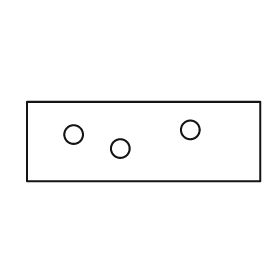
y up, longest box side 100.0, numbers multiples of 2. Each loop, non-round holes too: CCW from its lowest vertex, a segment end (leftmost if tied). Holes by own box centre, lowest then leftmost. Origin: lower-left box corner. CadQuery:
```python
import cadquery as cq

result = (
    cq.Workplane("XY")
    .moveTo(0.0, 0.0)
    .lineTo(100.0, 0.0)
    .lineTo(100.0, 34.0)
    .lineTo(0.0, 34.0)
    .close()
    .moveTo(40.0, 14.0)
    .circle(4.0)
    .moveTo(20.0, 20.0)
    .circle(4.0)
    .moveTo(70.0, 22.0)
    .circle(4.0)
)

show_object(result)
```